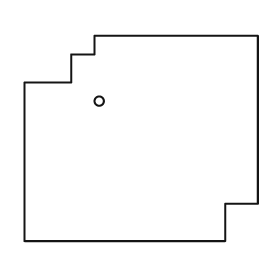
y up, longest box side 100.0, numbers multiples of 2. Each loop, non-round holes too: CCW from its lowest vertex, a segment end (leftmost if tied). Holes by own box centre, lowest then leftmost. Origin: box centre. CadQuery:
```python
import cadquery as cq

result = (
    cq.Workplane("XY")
    .moveTo(-50.0, -44.0)
    .lineTo(36.0, -44.0)
    .lineTo(36.0, -28.0)
    .lineTo(50.0, -28.0)
    .lineTo(50.0, 44.0)
    .lineTo(-20.0, 44.0)
    .lineTo(-20.0, 36.0)
    .lineTo(-30.0, 36.0)
    .lineTo(-30.0, 24.0)
    .lineTo(-50.0, 24.0)
    .close()
    .moveTo(-18.0, 16.0)
    .circle(2.0)
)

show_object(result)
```